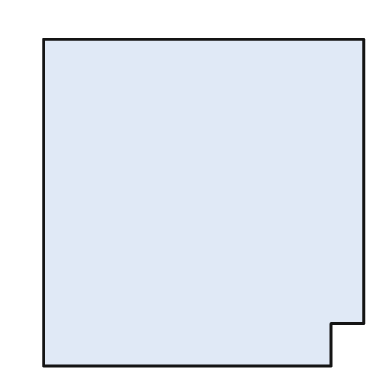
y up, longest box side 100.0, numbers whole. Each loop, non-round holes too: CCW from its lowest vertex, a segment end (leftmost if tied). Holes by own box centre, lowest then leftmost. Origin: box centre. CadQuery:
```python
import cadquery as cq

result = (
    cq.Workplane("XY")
    .moveTo(-49.0, -50.0)
    .lineTo(39.0, -50.0)
    .lineTo(39.0, -37.0)
    .lineTo(49.0, -37.0)
    .lineTo(49.0, 50.0)
    .lineTo(-49.0, 50.0)
    .close()
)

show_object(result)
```